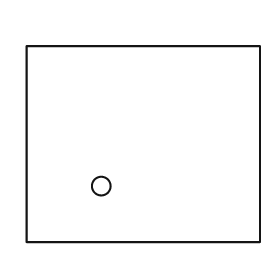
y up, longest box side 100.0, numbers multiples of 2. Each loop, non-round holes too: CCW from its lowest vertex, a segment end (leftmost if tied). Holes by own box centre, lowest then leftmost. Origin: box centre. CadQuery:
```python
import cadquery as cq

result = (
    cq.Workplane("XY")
    .moveTo(-50.0, -42.0)
    .lineTo(50.0, -42.0)
    .lineTo(50.0, 42.0)
    .lineTo(-50.0, 42.0)
    .close()
    .moveTo(-18.0, -18.0)
    .circle(4.0)
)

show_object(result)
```